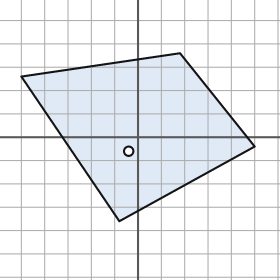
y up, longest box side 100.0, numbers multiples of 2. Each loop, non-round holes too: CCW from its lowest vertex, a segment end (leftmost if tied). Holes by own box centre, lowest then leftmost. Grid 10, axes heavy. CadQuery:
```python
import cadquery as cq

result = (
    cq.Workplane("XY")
    .moveTo(-8.0, -36.0)
    .lineTo(50.0, -4.0)
    .lineTo(18.0, 36.0)
    .lineTo(-50.0, 26.0)
    .close()
    .moveTo(-4.0, -6.0)
    .circle(2.0)
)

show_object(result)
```